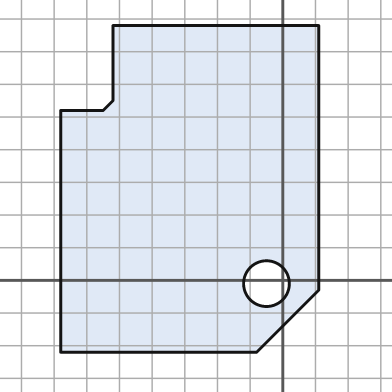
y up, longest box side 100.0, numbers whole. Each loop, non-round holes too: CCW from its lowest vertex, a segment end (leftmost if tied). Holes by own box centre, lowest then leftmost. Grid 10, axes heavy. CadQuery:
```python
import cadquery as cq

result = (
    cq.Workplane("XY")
    .moveTo(-68.0, -22.0)
    .lineTo(-8.0, -22.0)
    .lineTo(11.0, -3.0)
    .lineTo(11.0, 78.0)
    .lineTo(-52.0, 78.0)
    .lineTo(-52.0, 55.0)
    .lineTo(-55.0, 52.0)
    .lineTo(-68.0, 52.0)
    .close()
    .moveTo(-5.0, -1.0)
    .circle(7.0)
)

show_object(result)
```